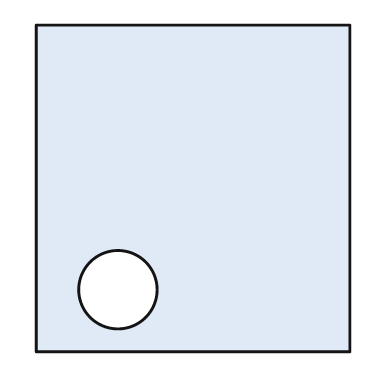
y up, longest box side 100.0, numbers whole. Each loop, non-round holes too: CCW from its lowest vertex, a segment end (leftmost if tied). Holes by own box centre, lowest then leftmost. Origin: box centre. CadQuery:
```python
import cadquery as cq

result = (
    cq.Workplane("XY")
    .moveTo(-48.0, -50.0)
    .lineTo(48.0, -50.0)
    .lineTo(48.0, 50.0)
    .lineTo(-48.0, 50.0)
    .close()
    .moveTo(-23.0, -31.0)
    .circle(12.0)
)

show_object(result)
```